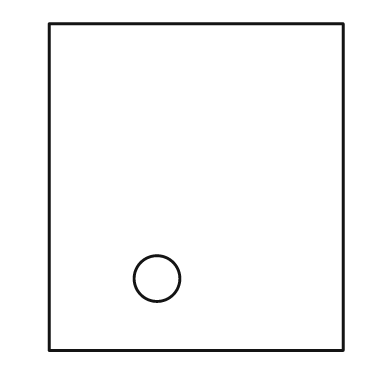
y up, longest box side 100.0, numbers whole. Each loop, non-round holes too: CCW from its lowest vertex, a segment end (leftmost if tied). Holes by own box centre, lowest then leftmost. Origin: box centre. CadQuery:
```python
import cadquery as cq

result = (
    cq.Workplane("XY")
    .moveTo(-45.0, -50.0)
    .lineTo(45.0, -50.0)
    .lineTo(45.0, 50.0)
    .lineTo(-45.0, 50.0)
    .close()
    .moveTo(-12.0, -28.0)
    .circle(7.0)
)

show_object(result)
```